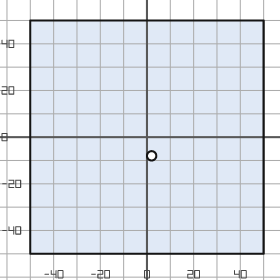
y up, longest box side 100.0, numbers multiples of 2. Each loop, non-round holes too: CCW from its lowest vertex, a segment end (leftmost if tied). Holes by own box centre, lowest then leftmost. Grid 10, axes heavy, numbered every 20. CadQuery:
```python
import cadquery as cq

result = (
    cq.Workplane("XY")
    .moveTo(-50.0, -50.0)
    .lineTo(50.0, -50.0)
    .lineTo(50.0, 50.0)
    .lineTo(-50.0, 50.0)
    .close()
    .moveTo(2.0, -8.0)
    .circle(2.0)
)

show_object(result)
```